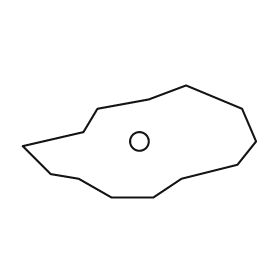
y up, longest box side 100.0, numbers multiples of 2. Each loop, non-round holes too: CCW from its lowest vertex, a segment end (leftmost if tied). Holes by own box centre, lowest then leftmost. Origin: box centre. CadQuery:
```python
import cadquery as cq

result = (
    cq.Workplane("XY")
    .moveTo(-12.0, -24.0)
    .lineTo(6.0, -24.0)
    .lineTo(18.0, -16.0)
    .lineTo(42.0, -10.0)
    .lineTo(50.0, 0.0)
    .lineTo(44.0, 14.0)
    .lineTo(20.0, 24.0)
    .lineTo(4.0, 18.0)
    .lineTo(-18.0, 14.0)
    .lineTo(-24.0, 4.0)
    .lineTo(-50.0, -2.0)
    .lineTo(-38.0, -14.0)
    .lineTo(-26.0, -16.0)
    .close()
    .moveTo(0.0, 0.0)
    .circle(4.0)
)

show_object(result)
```